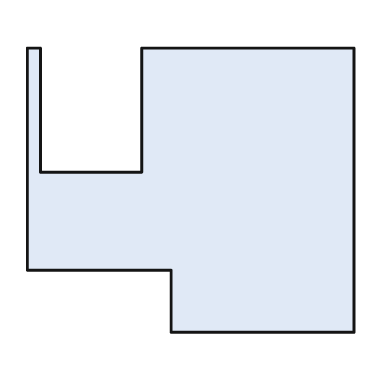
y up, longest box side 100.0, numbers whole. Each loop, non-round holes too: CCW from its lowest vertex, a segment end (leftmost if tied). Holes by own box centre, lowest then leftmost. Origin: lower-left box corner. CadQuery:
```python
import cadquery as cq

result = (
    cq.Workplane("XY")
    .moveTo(44.0, 0.0)
    .lineTo(100.0, 0.0)
    .lineTo(100.0, 87.0)
    .lineTo(35.0, 87.0)
    .lineTo(35.0, 49.0)
    .lineTo(4.0, 49.0)
    .lineTo(4.0, 87.0)
    .lineTo(0.0, 87.0)
    .lineTo(0.0, 19.0)
    .lineTo(44.0, 19.0)
    .close()
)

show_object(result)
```